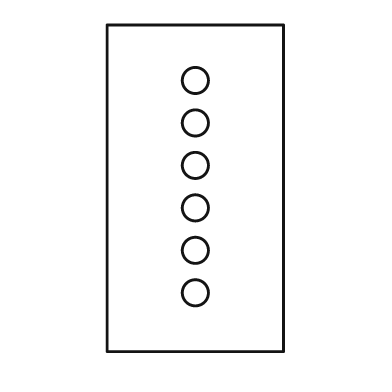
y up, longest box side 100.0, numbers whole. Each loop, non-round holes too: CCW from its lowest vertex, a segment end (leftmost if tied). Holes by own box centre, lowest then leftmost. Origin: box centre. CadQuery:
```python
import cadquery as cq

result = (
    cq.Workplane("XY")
    .moveTo(-27.0, -50.0)
    .lineTo(27.0, -50.0)
    .lineTo(27.0, 50.0)
    .lineTo(-27.0, 50.0)
    .close()
    .moveTo(0.0, -32.0)
    .circle(4.0)
    .moveTo(0.0, -19.0)
    .circle(4.0)
    .moveTo(0.0, -6.0)
    .circle(4.0)
    .moveTo(0.0, 7.0)
    .circle(4.0)
    .moveTo(0.0, 20.0)
    .circle(4.0)
    .moveTo(0.0, 33.0)
    .circle(4.0)
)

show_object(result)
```